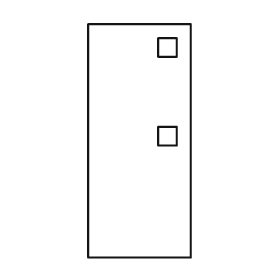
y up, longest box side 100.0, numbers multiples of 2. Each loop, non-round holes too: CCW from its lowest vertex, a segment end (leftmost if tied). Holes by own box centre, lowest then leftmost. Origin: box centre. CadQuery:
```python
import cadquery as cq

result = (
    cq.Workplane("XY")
    .moveTo(-22.0, -50.0)
    .lineTo(22.0, -50.0)
    .lineTo(22.0, 50.0)
    .lineTo(-22.0, 50.0)
    .close()
    .moveTo(8.0, -2.0)
    .lineTo(16.0, -2.0)
    .lineTo(16.0, 6.0)
    .lineTo(8.0, 6.0)
    .close()
    .moveTo(8.0, 36.0)
    .lineTo(16.0, 36.0)
    .lineTo(16.0, 44.0)
    .lineTo(8.0, 44.0)
    .close()
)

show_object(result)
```